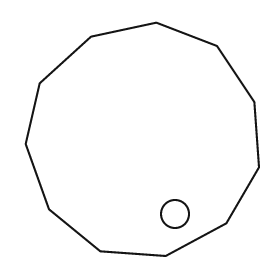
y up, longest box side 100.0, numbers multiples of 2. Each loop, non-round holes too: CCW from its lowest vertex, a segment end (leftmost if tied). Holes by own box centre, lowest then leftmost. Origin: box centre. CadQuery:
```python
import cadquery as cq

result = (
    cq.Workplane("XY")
    .moveTo(10.0, -50.0)
    .lineTo(36.0, -36.0)
    .lineTo(50.0, -12.0)
    .lineTo(48.0, 16.0)
    .lineTo(32.0, 40.0)
    .lineTo(6.0, 50.0)
    .lineTo(-22.0, 44.0)
    .lineTo(-44.0, 24.0)
    .lineTo(-50.0, -2.0)
    .lineTo(-40.0, -30.0)
    .lineTo(-18.0, -48.0)
    .close()
    .moveTo(14.0, -32.0)
    .circle(6.0)
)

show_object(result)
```